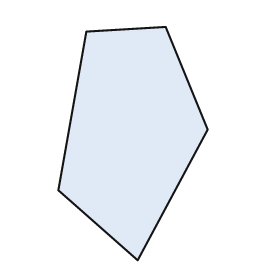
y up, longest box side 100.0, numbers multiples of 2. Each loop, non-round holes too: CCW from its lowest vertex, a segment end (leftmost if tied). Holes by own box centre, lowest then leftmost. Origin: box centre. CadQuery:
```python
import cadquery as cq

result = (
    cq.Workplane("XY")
    .moveTo(2.0, -50.0)
    .lineTo(32.0, 6.0)
    .lineTo(14.0, 50.0)
    .lineTo(-20.0, 48.0)
    .lineTo(-32.0, -20.0)
    .close()
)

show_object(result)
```